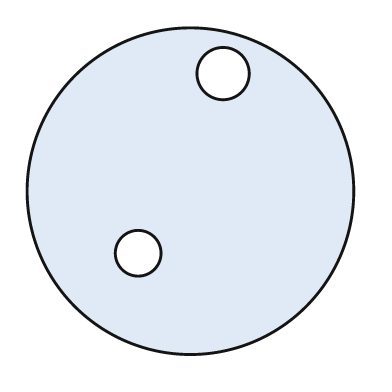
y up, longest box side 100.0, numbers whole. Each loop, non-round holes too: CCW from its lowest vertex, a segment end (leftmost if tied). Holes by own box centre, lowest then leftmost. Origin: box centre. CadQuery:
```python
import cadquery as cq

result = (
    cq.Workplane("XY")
    .moveTo(0.0, 0.0)
    .circle(50.0)
    .moveTo(-16.0, -19.0)
    .circle(7.0)
    .moveTo(10.0, 36.0)
    .circle(8.0)
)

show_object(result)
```